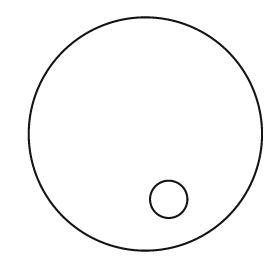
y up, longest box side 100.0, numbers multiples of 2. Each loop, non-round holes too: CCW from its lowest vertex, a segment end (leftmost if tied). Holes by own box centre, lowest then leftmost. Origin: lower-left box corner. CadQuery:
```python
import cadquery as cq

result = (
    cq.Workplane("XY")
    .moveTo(50.0, 50.0)
    .circle(50.0)
    .moveTo(60.0, 22.0)
    .circle(8.0)
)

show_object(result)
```